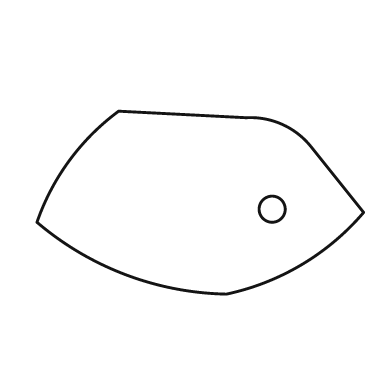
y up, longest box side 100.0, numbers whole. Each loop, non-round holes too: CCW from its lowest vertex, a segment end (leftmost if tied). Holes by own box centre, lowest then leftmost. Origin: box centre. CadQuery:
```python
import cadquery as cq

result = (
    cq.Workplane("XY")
    .moveTo(8.0, -28.0)
    .threePointArc((31.0, -19.0), (50.0, -3.0))
    .lineTo(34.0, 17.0)
    .threePointArc((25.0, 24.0), (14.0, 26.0))
    .lineTo(-25.0, 28.0)
    .threePointArc((-40.0, 13.0), (-50.0, -6.0))
    .threePointArc((-23.0, -22.0), (8.0, -28.0))
    .close()
    .moveTo(22.0, -2.0)
    .circle(4.0)
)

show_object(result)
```